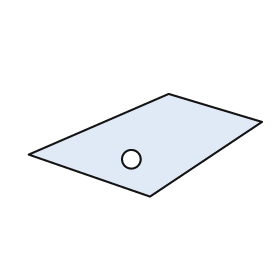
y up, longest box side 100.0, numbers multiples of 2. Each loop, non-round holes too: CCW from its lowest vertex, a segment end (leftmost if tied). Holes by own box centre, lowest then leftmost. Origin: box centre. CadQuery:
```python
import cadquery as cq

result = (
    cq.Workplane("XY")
    .moveTo(2.0, -22.0)
    .lineTo(50.0, 10.0)
    .lineTo(10.0, 22.0)
    .lineTo(-50.0, -4.0)
    .close()
    .moveTo(-6.0, -6.0)
    .circle(4.0)
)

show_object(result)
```